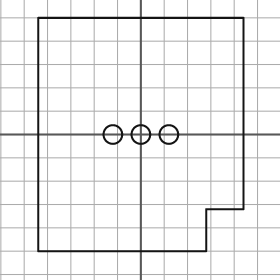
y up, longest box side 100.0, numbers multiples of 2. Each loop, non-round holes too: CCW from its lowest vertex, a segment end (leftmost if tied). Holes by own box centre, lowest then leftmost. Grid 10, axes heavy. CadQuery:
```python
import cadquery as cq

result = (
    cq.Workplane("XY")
    .moveTo(-44.0, -50.0)
    .lineTo(28.0, -50.0)
    .lineTo(28.0, -32.0)
    .lineTo(44.0, -32.0)
    .lineTo(44.0, 50.0)
    .lineTo(-44.0, 50.0)
    .close()
    .moveTo(-12.0, 0.0)
    .circle(4.0)
    .moveTo(0.0, 0.0)
    .circle(4.0)
    .moveTo(12.0, 0.0)
    .circle(4.0)
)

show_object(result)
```